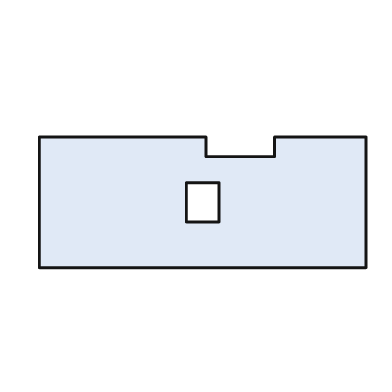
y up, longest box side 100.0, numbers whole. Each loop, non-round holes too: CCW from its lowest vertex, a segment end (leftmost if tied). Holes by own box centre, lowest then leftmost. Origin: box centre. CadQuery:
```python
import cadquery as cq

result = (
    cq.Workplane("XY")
    .moveTo(-50.0, -20.0)
    .lineTo(50.0, -20.0)
    .lineTo(50.0, 20.0)
    .lineTo(22.0, 20.0)
    .lineTo(22.0, 14.0)
    .lineTo(1.0, 14.0)
    .lineTo(1.0, 20.0)
    .lineTo(-50.0, 20.0)
    .close()
    .moveTo(-5.0, -6.0)
    .lineTo(5.0, -6.0)
    .lineTo(5.0, 6.0)
    .lineTo(-5.0, 6.0)
    .close()
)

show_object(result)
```